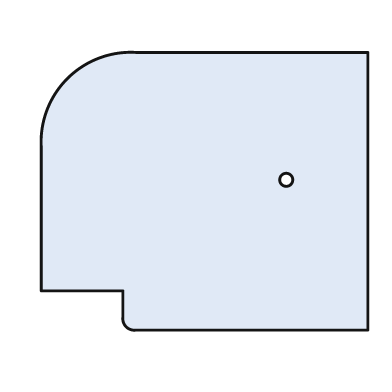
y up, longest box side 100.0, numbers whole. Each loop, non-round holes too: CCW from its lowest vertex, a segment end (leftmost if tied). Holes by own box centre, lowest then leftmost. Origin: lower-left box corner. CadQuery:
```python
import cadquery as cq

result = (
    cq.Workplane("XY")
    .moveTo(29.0, 0.0)
    .lineTo(100.0, 0.0)
    .lineTo(100.0, 85.0)
    .lineTo(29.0, 85.0)
    .threePointArc((8.0, 77.0), (0.0, 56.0))
    .lineTo(0.0, 12.0)
    .lineTo(25.0, 12.0)
    .lineTo(25.0, 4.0)
    .threePointArc((26.0, 1.0), (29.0, 0.0))
    .close()
    .moveTo(75.0, 46.0)
    .circle(2.0)
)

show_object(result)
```